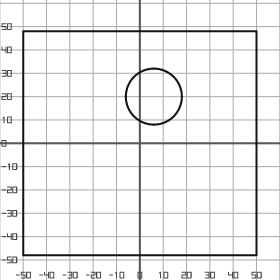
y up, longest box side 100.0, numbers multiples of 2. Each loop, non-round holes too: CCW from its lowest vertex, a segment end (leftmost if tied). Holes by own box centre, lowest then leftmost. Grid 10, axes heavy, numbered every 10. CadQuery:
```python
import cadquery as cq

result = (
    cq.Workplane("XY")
    .moveTo(-50.0, -48.0)
    .lineTo(50.0, -48.0)
    .lineTo(50.0, 48.0)
    .lineTo(-50.0, 48.0)
    .close()
    .moveTo(6.0, 20.0)
    .circle(12.0)
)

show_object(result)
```